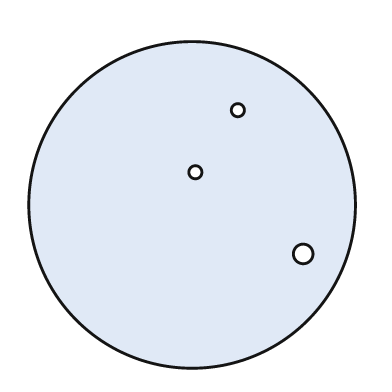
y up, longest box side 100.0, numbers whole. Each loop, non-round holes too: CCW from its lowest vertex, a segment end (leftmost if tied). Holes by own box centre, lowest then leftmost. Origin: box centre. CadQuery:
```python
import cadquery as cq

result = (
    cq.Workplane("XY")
    .moveTo(0.0, 0.0)
    .circle(50.0)
    .moveTo(34.0, -15.0)
    .circle(3.0)
    .moveTo(1.0, 10.0)
    .circle(2.0)
    .moveTo(14.0, 29.0)
    .circle(2.0)
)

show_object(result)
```